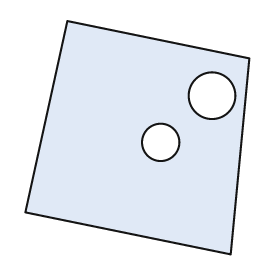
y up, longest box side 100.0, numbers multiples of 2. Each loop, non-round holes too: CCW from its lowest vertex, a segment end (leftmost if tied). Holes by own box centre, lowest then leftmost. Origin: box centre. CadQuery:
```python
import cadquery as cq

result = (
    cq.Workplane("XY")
    .moveTo(40.0, -50.0)
    .lineTo(48.0, 34.0)
    .lineTo(-30.0, 50.0)
    .lineTo(-48.0, -32.0)
    .close()
    .moveTo(10.0, -2.0)
    .circle(8.0)
    .moveTo(32.0, 18.0)
    .circle(10.0)
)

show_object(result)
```